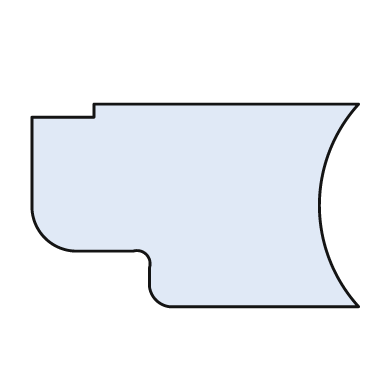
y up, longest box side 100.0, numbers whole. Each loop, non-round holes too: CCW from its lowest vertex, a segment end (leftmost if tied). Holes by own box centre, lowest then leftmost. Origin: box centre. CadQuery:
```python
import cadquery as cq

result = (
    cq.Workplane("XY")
    .moveTo(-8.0, -31.0)
    .lineTo(50.0, -31.0)
    .threePointArc((38.0, 0.0), (50.0, 31.0))
    .lineTo(-31.0, 31.0)
    .lineTo(-31.0, 27.0)
    .lineTo(-50.0, 27.0)
    .lineTo(-50.0, 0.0)
    .threePointArc((-46.0, -10.0), (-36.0, -14.0))
    .lineTo(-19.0, -14.0)
    .threePointArc((-15.0, -15.0), (-14.0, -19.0))
    .lineTo(-14.0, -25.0)
    .threePointArc((-12.0, -29.0), (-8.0, -31.0))
    .close()
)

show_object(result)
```